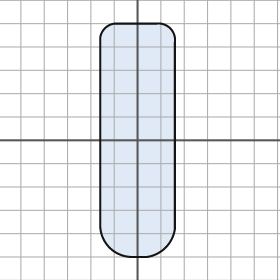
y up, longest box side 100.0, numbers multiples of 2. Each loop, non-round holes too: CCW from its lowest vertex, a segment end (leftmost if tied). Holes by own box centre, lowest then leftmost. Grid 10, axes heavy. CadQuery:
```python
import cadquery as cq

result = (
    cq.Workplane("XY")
    .moveTo(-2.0, -50.0)
    .lineTo(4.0, -50.0)
    .threePointArc((12.0, -46.0), (16.0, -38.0))
    .lineTo(16.0, 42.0)
    .threePointArc((14.0, 48.0), (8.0, 50.0))
    .lineTo(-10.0, 50.0)
    .threePointArc((-14.0, 48.0), (-16.0, 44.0))
    .lineTo(-16.0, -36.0)
    .threePointArc((-12.0, -46.0), (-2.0, -50.0))
    .close()
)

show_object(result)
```